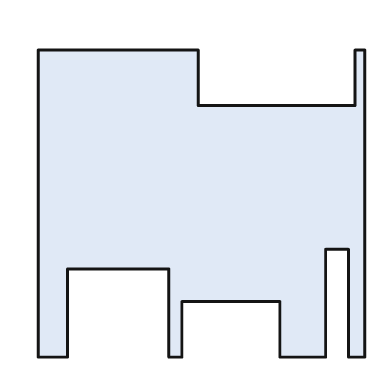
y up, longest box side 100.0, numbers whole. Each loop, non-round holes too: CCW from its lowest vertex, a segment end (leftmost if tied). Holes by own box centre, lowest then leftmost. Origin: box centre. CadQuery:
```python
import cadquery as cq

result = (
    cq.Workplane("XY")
    .moveTo(-50.0, -47.0)
    .lineTo(-41.0, -47.0)
    .lineTo(-41.0, -20.0)
    .lineTo(-10.0, -20.0)
    .lineTo(-10.0, -47.0)
    .lineTo(-6.0, -47.0)
    .lineTo(-6.0, -30.0)
    .lineTo(24.0, -30.0)
    .lineTo(24.0, -47.0)
    .lineTo(38.0, -47.0)
    .lineTo(38.0, -14.0)
    .lineTo(45.0, -14.0)
    .lineTo(45.0, -47.0)
    .lineTo(50.0, -47.0)
    .lineTo(50.0, 47.0)
    .lineTo(47.0, 47.0)
    .lineTo(47.0, 30.0)
    .lineTo(-1.0, 30.0)
    .lineTo(-1.0, 47.0)
    .lineTo(-50.0, 47.0)
    .close()
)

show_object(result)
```